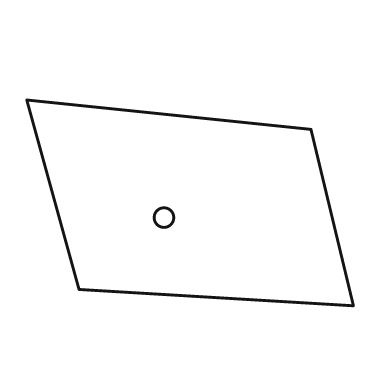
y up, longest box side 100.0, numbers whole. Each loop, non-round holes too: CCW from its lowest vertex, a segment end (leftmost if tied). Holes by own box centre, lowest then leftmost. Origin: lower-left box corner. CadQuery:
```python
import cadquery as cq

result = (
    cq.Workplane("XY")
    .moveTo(100.0, 0.0)
    .lineTo(87.0, 54.0)
    .lineTo(0.0, 63.0)
    .lineTo(16.0, 5.0)
    .close()
    .moveTo(42.0, 27.0)
    .circle(3.0)
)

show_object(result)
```